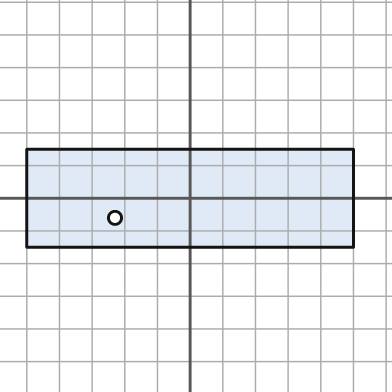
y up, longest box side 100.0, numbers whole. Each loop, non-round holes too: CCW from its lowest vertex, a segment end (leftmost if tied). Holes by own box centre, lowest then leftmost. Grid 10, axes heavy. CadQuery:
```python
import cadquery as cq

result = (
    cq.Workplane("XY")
    .moveTo(-50.0, -15.0)
    .lineTo(50.0, -15.0)
    .lineTo(50.0, 15.0)
    .lineTo(-50.0, 15.0)
    .close()
    .moveTo(-23.0, -6.0)
    .circle(2.0)
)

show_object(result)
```